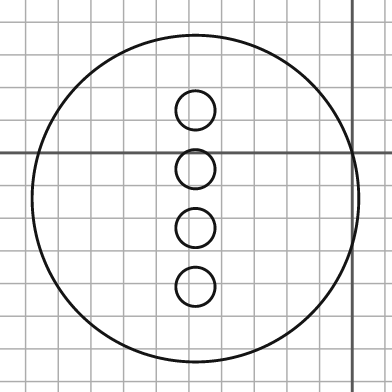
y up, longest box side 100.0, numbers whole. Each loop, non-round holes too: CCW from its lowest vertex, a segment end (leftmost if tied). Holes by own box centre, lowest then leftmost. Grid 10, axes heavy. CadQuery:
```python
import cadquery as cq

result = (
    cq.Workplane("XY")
    .moveTo(-48.0, -14.0)
    .circle(50.0)
    .moveTo(-48.0, -41.0)
    .circle(6.0)
    .moveTo(-48.0, -23.0)
    .circle(6.0)
    .moveTo(-48.0, -5.0)
    .circle(6.0)
    .moveTo(-48.0, 13.0)
    .circle(6.0)
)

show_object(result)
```